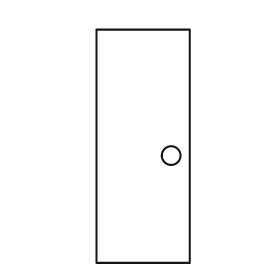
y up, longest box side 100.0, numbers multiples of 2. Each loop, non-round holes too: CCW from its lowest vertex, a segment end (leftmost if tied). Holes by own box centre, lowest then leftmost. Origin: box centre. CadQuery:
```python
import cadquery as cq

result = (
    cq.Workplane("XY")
    .moveTo(-20.0, -50.0)
    .lineTo(20.0, -50.0)
    .lineTo(20.0, 50.0)
    .lineTo(-20.0, 50.0)
    .close()
    .moveTo(12.0, -4.0)
    .circle(4.0)
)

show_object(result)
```